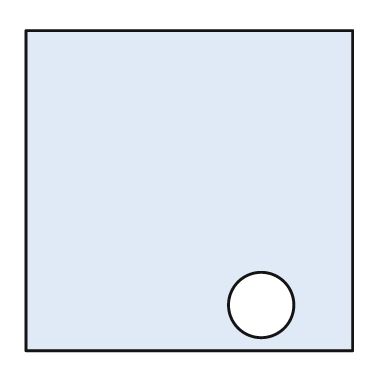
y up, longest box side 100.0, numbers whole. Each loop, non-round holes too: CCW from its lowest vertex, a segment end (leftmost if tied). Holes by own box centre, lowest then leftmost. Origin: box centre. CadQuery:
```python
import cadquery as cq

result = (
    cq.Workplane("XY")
    .moveTo(-50.0, -49.0)
    .lineTo(50.0, -49.0)
    .lineTo(50.0, 49.0)
    .lineTo(-50.0, 49.0)
    .close()
    .moveTo(22.0, -35.0)
    .circle(10.0)
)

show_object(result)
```